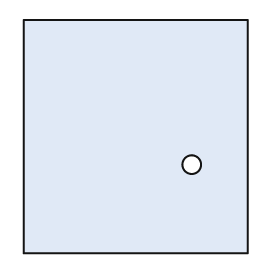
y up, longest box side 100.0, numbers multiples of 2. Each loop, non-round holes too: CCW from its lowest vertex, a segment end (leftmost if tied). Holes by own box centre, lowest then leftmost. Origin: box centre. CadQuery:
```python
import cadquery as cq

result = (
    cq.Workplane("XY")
    .moveTo(-48.0, -50.0)
    .lineTo(48.0, -50.0)
    .lineTo(48.0, 50.0)
    .lineTo(-48.0, 50.0)
    .close()
    .moveTo(24.0, -12.0)
    .circle(4.0)
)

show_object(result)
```